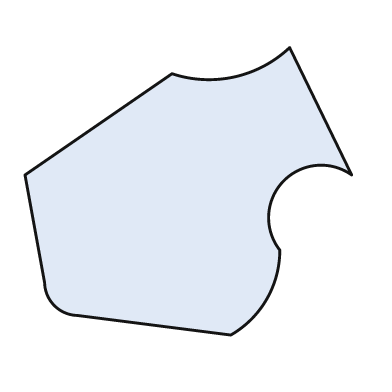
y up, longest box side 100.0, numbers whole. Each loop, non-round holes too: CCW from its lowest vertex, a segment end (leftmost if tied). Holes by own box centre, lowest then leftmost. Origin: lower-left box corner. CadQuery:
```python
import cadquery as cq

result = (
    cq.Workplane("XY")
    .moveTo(63.0, 0.0)
    .threePointArc((74.0, 11.0), (78.0, 26.0))
    .threePointArc((79.0, 47.0), (100.0, 49.0))
    .lineTo(81.0, 88.0)
    .threePointArc((64.0, 79.0), (45.0, 80.0))
    .lineTo(0.0, 49.0)
    .lineTo(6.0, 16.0)
    .threePointArc((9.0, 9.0), (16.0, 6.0))
    .close()
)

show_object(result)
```